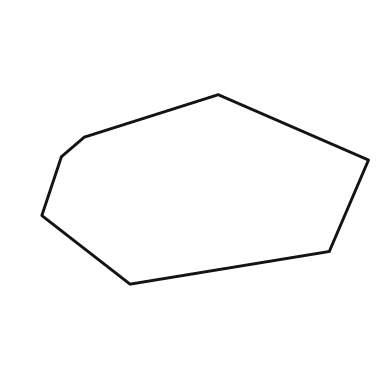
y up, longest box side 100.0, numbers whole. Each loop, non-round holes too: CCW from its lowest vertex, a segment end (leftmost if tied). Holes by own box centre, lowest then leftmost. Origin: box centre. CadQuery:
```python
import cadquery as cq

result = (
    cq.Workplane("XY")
    .moveTo(-23.0, -29.0)
    .lineTo(38.0, -19.0)
    .lineTo(50.0, 9.0)
    .lineTo(4.0, 29.0)
    .lineTo(-37.0, 16.0)
    .lineTo(-44.0, 10.0)
    .lineTo(-50.0, -8.0)
    .close()
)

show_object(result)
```